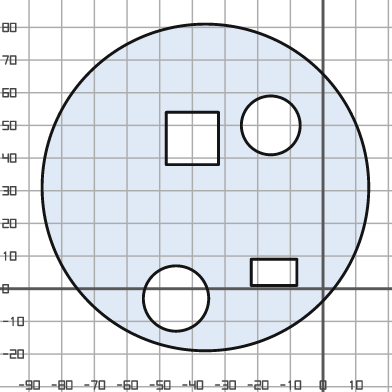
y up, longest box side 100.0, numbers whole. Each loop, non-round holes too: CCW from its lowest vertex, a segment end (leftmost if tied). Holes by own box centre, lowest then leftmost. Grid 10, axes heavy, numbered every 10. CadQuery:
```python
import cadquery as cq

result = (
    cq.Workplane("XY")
    .moveTo(-36.0, 31.0)
    .circle(50.0)
    .moveTo(-45.0, -3.0)
    .circle(10.0)
    .moveTo(-22.0, 1.0)
    .lineTo(-8.0, 1.0)
    .lineTo(-8.0, 9.0)
    .lineTo(-22.0, 9.0)
    .close()
    .moveTo(-48.0, 38.0)
    .lineTo(-32.0, 38.0)
    .lineTo(-32.0, 54.0)
    .lineTo(-48.0, 54.0)
    .close()
    .moveTo(-16.0, 50.0)
    .circle(9.0)
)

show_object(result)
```